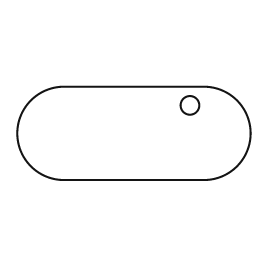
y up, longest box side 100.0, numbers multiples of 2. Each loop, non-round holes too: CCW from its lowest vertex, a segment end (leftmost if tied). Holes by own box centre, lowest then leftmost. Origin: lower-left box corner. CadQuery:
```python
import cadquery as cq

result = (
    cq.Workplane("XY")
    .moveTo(20.0, 0.0)
    .lineTo(80.0, 0.0)
    .threePointArc((100.0, 20.0), (80.0, 40.0))
    .lineTo(20.0, 40.0)
    .threePointArc((0.0, 20.0), (20.0, 0.0))
    .close()
    .moveTo(74.0, 32.0)
    .circle(4.0)
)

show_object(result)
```